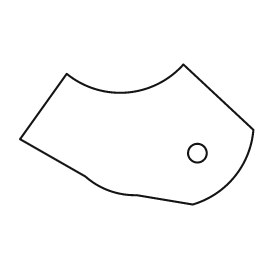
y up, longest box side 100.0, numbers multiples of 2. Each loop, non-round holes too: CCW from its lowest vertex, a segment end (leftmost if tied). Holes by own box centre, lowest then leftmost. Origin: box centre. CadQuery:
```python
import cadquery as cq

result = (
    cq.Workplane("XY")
    .moveTo(24.0, -30.0)
    .threePointArc((42.0, -18.0), (50.0, 2.0))
    .lineTo(20.0, 30.0)
    .threePointArc((-4.0, 18.0), (-30.0, 26.0))
    .lineTo(-50.0, -2.0)
    .lineTo(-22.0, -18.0)
    .threePointArc((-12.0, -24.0), (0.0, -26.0))
    .close()
    .moveTo(26.0, -8.0)
    .circle(4.0)
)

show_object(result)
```